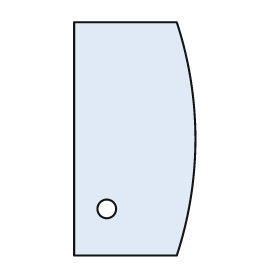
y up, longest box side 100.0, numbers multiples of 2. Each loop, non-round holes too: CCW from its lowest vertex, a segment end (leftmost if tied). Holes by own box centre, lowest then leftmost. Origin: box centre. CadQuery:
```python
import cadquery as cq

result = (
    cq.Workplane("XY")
    .moveTo(-26.0, -50.0)
    .lineTo(18.0, -50.0)
    .threePointArc((26.0, 0.0), (18.0, 50.0))
    .lineTo(-26.0, 50.0)
    .close()
    .moveTo(-12.0, -30.0)
    .circle(4.0)
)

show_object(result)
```